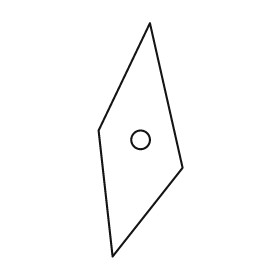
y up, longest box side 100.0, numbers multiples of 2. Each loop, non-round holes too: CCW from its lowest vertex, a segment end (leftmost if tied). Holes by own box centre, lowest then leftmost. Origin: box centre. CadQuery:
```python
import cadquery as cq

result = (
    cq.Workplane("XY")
    .moveTo(-12.0, -50.0)
    .lineTo(18.0, -12.0)
    .lineTo(4.0, 50.0)
    .lineTo(-18.0, 4.0)
    .close()
    .moveTo(0.0, 0.0)
    .circle(4.0)
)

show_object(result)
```